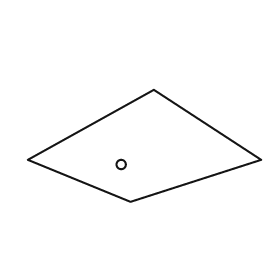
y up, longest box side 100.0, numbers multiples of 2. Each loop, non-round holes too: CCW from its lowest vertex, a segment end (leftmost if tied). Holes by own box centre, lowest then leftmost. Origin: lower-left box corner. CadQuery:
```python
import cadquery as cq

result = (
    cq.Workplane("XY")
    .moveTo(44.0, 0.0)
    .lineTo(100.0, 18.0)
    .lineTo(54.0, 48.0)
    .lineTo(0.0, 18.0)
    .close()
    .moveTo(40.0, 16.0)
    .circle(2.0)
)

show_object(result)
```